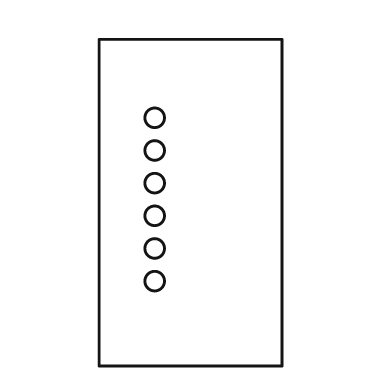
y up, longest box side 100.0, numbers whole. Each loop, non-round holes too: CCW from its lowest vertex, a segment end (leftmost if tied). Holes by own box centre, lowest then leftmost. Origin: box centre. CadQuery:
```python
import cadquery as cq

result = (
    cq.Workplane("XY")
    .moveTo(-28.0, -50.0)
    .lineTo(28.0, -50.0)
    .lineTo(28.0, 50.0)
    .lineTo(-28.0, 50.0)
    .close()
    .moveTo(-11.0, -24.0)
    .circle(3.0)
    .moveTo(-11.0, -14.0)
    .circle(3.0)
    .moveTo(-11.0, -4.0)
    .circle(3.0)
    .moveTo(-11.0, 6.0)
    .circle(3.0)
    .moveTo(-11.0, 16.0)
    .circle(3.0)
    .moveTo(-11.0, 26.0)
    .circle(3.0)
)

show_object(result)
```